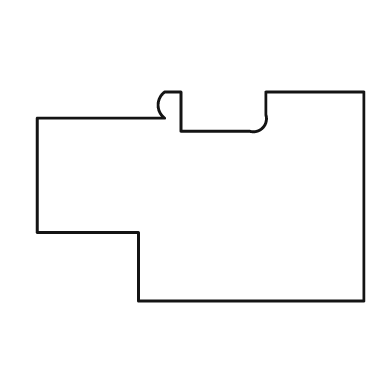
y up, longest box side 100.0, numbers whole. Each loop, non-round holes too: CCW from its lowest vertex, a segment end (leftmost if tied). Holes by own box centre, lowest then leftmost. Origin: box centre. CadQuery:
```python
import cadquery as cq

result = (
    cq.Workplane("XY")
    .moveTo(-19.0, -32.0)
    .lineTo(50.0, -32.0)
    .lineTo(50.0, 32.0)
    .lineTo(20.0, 32.0)
    .lineTo(20.0, 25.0)
    .threePointArc((19.0, 21.0), (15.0, 20.0))
    .lineTo(-6.0, 20.0)
    .lineTo(-6.0, 32.0)
    .lineTo(-11.0, 32.0)
    .threePointArc((-13.0, 28.0), (-11.0, 24.0))
    .lineTo(-50.0, 24.0)
    .lineTo(-50.0, -11.0)
    .lineTo(-19.0, -11.0)
    .close()
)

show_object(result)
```